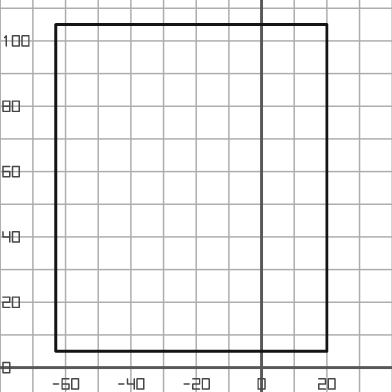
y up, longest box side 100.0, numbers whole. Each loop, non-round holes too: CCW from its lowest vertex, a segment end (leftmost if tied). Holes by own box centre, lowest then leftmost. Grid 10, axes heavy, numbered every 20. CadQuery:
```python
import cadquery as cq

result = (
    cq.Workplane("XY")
    .moveTo(-63.0, 5.0)
    .lineTo(20.0, 5.0)
    .lineTo(20.0, 105.0)
    .lineTo(-63.0, 105.0)
    .close()
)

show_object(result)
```